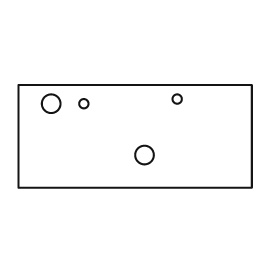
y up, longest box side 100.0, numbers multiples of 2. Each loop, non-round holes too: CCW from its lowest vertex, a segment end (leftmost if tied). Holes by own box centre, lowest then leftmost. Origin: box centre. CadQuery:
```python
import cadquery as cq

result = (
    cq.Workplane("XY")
    .moveTo(-50.0, -22.0)
    .lineTo(50.0, -22.0)
    .lineTo(50.0, 22.0)
    .lineTo(-50.0, 22.0)
    .close()
    .moveTo(4.0, -8.0)
    .circle(4.0)
    .moveTo(-36.0, 14.0)
    .circle(4.0)
    .moveTo(-22.0, 14.0)
    .circle(2.0)
    .moveTo(18.0, 16.0)
    .circle(2.0)
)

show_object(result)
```